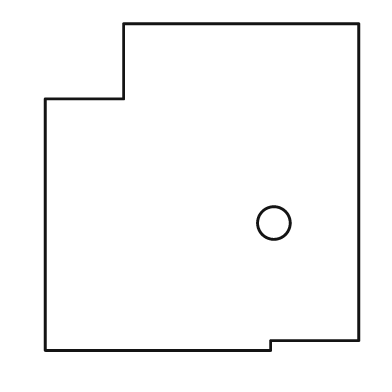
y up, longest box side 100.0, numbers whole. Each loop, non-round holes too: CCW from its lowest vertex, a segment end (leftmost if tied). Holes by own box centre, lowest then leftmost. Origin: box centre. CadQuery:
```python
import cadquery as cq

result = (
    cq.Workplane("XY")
    .moveTo(-48.0, -50.0)
    .lineTo(21.0, -50.0)
    .lineTo(21.0, -47.0)
    .lineTo(48.0, -47.0)
    .lineTo(48.0, 50.0)
    .lineTo(-24.0, 50.0)
    .lineTo(-24.0, 27.0)
    .lineTo(-48.0, 27.0)
    .close()
    .moveTo(22.0, -11.0)
    .circle(5.0)
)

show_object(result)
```